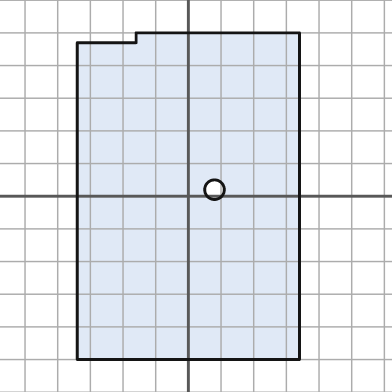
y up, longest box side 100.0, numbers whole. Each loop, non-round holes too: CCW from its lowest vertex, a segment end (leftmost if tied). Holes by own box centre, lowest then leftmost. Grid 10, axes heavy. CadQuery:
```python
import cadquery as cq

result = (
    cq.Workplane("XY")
    .moveTo(-34.0, -50.0)
    .lineTo(34.0, -50.0)
    .lineTo(34.0, 50.0)
    .lineTo(-16.0, 50.0)
    .lineTo(-16.0, 47.0)
    .lineTo(-34.0, 47.0)
    .close()
    .moveTo(8.0, 2.0)
    .circle(3.0)
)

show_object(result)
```